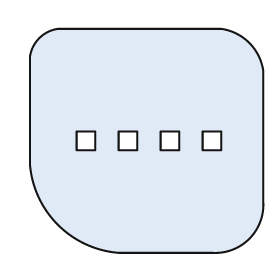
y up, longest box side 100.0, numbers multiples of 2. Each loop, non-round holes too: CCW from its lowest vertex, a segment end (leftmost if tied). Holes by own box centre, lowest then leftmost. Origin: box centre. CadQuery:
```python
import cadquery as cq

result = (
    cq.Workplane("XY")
    .moveTo(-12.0, -48.0)
    .lineTo(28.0, -48.0)
    .threePointArc((44.0, -42.0), (50.0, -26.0))
    .lineTo(50.0, 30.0)
    .threePointArc((44.0, 42.0), (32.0, 48.0))
    .lineTo(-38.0, 48.0)
    .threePointArc((-46.0, 44.0), (-50.0, 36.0))
    .lineTo(-50.0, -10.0)
    .threePointArc((-38.0, -36.0), (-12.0, -48.0))
    .close()
    .moveTo(-30.0, -4.0)
    .lineTo(-22.0, -4.0)
    .lineTo(-22.0, 4.0)
    .lineTo(-30.0, 4.0)
    .close()
    .moveTo(-12.0, -4.0)
    .lineTo(-4.0, -4.0)
    .lineTo(-4.0, 4.0)
    .lineTo(-12.0, 4.0)
    .close()
    .moveTo(6.0, -4.0)
    .lineTo(14.0, -4.0)
    .lineTo(14.0, 4.0)
    .lineTo(6.0, 4.0)
    .close()
    .moveTo(24.0, -4.0)
    .lineTo(32.0, -4.0)
    .lineTo(32.0, 4.0)
    .lineTo(24.0, 4.0)
    .close()
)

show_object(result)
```